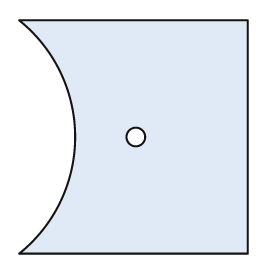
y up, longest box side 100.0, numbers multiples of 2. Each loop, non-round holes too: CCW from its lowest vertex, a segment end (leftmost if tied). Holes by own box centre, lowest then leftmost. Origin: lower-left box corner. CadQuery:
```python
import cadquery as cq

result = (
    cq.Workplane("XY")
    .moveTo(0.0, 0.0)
    .lineTo(98.0, 0.0)
    .lineTo(98.0, 100.0)
    .lineTo(0.0, 100.0)
    .threePointArc((24.0, 50.0), (0.0, 0.0))
    .close()
    .moveTo(50.0, 50.0)
    .circle(4.0)
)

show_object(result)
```